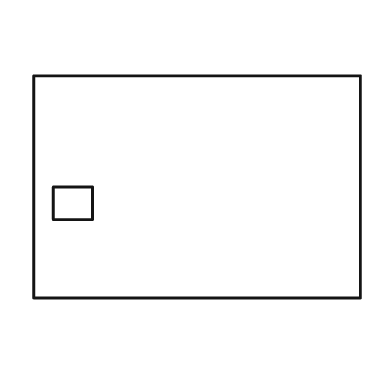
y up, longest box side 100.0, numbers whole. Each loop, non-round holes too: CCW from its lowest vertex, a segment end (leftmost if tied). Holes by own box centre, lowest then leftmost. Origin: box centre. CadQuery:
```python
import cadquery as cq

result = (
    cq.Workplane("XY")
    .moveTo(-50.0, -34.0)
    .lineTo(50.0, -34.0)
    .lineTo(50.0, 34.0)
    .lineTo(-50.0, 34.0)
    .close()
    .moveTo(-44.0, -10.0)
    .lineTo(-32.0, -10.0)
    .lineTo(-32.0, 0.0)
    .lineTo(-44.0, 0.0)
    .close()
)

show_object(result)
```